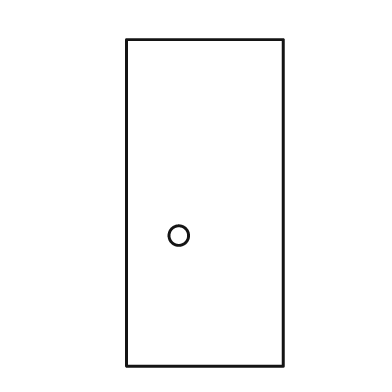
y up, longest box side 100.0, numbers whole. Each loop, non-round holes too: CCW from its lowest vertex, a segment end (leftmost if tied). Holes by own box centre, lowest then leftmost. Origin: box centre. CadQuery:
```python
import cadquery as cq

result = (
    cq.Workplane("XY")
    .moveTo(-24.0, -50.0)
    .lineTo(24.0, -50.0)
    .lineTo(24.0, 50.0)
    .lineTo(-24.0, 50.0)
    .close()
    .moveTo(-8.0, -10.0)
    .circle(3.0)
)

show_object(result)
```